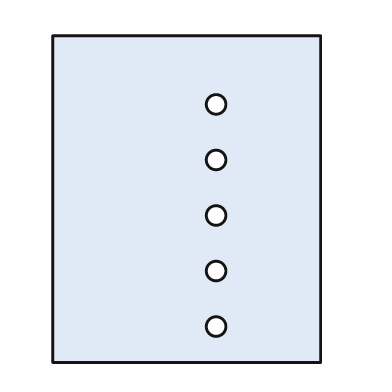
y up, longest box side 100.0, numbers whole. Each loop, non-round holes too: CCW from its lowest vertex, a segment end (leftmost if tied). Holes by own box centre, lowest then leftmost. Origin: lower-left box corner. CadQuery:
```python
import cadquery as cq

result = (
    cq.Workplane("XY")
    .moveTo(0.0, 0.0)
    .lineTo(82.0, 0.0)
    .lineTo(82.0, 100.0)
    .lineTo(0.0, 100.0)
    .close()
    .moveTo(50.0, 11.0)
    .circle(3.0)
    .moveTo(50.0, 28.0)
    .circle(3.0)
    .moveTo(50.0, 45.0)
    .circle(3.0)
    .moveTo(50.0, 62.0)
    .circle(3.0)
    .moveTo(50.0, 79.0)
    .circle(3.0)
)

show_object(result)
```